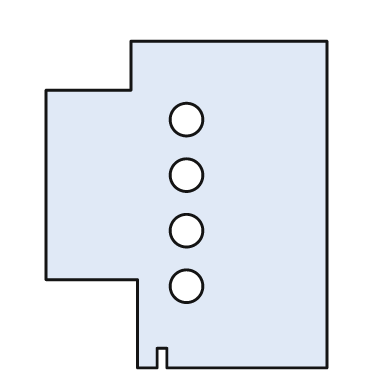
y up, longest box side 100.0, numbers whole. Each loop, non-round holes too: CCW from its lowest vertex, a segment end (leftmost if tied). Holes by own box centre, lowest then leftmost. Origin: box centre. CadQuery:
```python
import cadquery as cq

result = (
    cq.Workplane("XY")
    .moveTo(-15.0, -50.0)
    .lineTo(-9.0, -50.0)
    .lineTo(-9.0, -44.0)
    .lineTo(-6.0, -44.0)
    .lineTo(-6.0, -50.0)
    .lineTo(43.0, -50.0)
    .lineTo(43.0, 50.0)
    .lineTo(-17.0, 50.0)
    .lineTo(-17.0, 35.0)
    .lineTo(-43.0, 35.0)
    .lineTo(-43.0, -23.0)
    .lineTo(-15.0, -23.0)
    .close()
    .moveTo(0.0, -25.0)
    .circle(5.0)
    .moveTo(0.0, -8.0)
    .circle(5.0)
    .moveTo(0.0, 9.0)
    .circle(5.0)
    .moveTo(0.0, 26.0)
    .circle(5.0)
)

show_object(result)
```